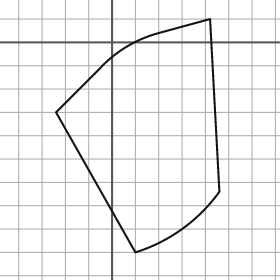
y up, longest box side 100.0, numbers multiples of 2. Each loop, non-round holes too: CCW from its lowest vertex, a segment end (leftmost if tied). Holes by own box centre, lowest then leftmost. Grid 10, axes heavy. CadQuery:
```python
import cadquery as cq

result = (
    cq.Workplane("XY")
    .moveTo(10.0, -90.0)
    .threePointArc((30.0, -80.0), (46.0, -64.0))
    .lineTo(42.0, 10.0)
    .lineTo(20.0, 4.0)
    .threePointArc((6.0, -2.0), (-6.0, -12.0))
    .lineTo(-24.0, -30.0)
    .close()
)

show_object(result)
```